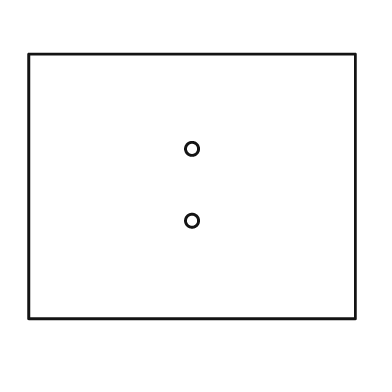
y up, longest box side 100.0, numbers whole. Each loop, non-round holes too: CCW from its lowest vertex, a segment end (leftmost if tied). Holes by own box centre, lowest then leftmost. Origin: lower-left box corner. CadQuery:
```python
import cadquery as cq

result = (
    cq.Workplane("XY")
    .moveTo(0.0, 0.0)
    .lineTo(100.0, 0.0)
    .lineTo(100.0, 81.0)
    .lineTo(0.0, 81.0)
    .close()
    .moveTo(50.0, 30.0)
    .circle(2.0)
    .moveTo(50.0, 52.0)
    .circle(2.0)
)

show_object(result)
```